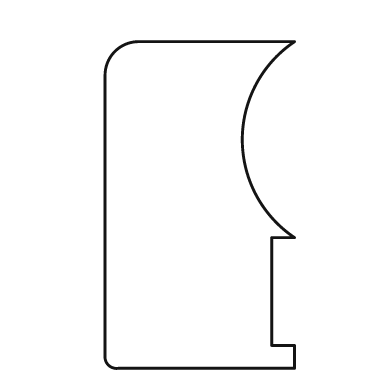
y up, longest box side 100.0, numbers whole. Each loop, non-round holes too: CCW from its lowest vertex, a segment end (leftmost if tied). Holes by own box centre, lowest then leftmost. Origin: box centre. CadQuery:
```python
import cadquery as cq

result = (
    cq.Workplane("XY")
    .moveTo(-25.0, -50.0)
    .lineTo(29.0, -50.0)
    .lineTo(29.0, -43.0)
    .lineTo(22.0, -43.0)
    .lineTo(22.0, -10.0)
    .lineTo(29.0, -10.0)
    .threePointArc((13.0, 20.0), (29.0, 50.0))
    .lineTo(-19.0, 50.0)
    .threePointArc((-26.0, 47.0), (-29.0, 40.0))
    .lineTo(-29.0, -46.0)
    .threePointArc((-28.0, -49.0), (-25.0, -50.0))
    .close()
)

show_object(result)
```